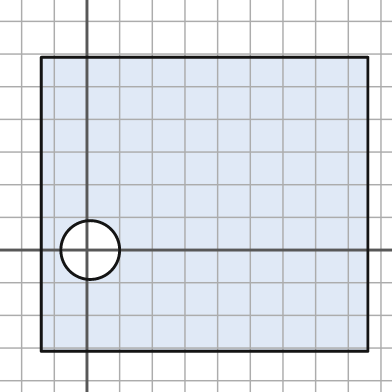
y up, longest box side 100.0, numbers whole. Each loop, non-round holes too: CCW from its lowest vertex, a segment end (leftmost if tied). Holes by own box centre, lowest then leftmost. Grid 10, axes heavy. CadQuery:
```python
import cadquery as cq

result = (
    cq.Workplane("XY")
    .moveTo(-14.0, -31.0)
    .lineTo(86.0, -31.0)
    .lineTo(86.0, 59.0)
    .lineTo(-14.0, 59.0)
    .close()
    .moveTo(1.0, 0.0)
    .circle(9.0)
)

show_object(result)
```